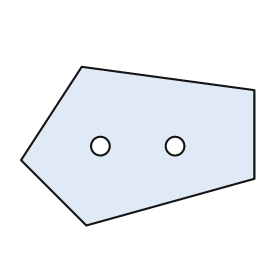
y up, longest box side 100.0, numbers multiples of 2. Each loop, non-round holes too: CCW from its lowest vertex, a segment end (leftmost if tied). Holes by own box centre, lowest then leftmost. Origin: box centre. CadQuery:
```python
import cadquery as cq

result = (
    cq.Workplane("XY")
    .moveTo(-22.0, -34.0)
    .lineTo(50.0, -14.0)
    .lineTo(50.0, 24.0)
    .lineTo(-24.0, 34.0)
    .lineTo(-50.0, -6.0)
    .close()
    .moveTo(-16.0, 0.0)
    .circle(4.0)
    .moveTo(16.0, 0.0)
    .circle(4.0)
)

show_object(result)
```